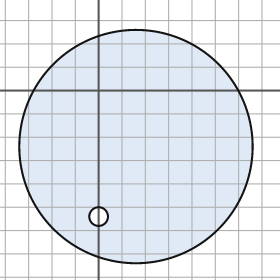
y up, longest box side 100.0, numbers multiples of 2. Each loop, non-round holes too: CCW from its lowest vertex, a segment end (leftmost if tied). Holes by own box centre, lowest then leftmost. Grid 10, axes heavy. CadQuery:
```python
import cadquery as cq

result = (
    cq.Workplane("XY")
    .moveTo(16.0, -24.0)
    .circle(50.0)
    .moveTo(0.0, -54.0)
    .circle(4.0)
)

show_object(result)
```